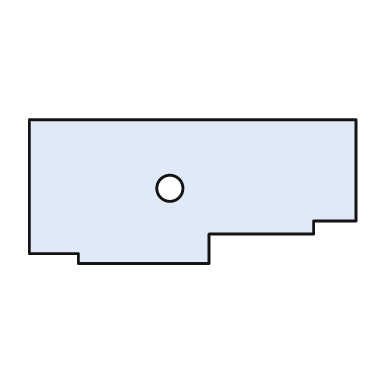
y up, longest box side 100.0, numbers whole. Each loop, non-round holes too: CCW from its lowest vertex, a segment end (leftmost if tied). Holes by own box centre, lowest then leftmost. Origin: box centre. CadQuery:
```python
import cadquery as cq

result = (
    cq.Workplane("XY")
    .moveTo(-35.0, -22.0)
    .lineTo(5.0, -22.0)
    .lineTo(5.0, -13.0)
    .lineTo(37.0, -13.0)
    .lineTo(37.0, -9.0)
    .lineTo(50.0, -9.0)
    .lineTo(50.0, 22.0)
    .lineTo(-50.0, 22.0)
    .lineTo(-50.0, -19.0)
    .lineTo(-35.0, -19.0)
    .close()
    .moveTo(-7.0, 1.0)
    .circle(4.0)
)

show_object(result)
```